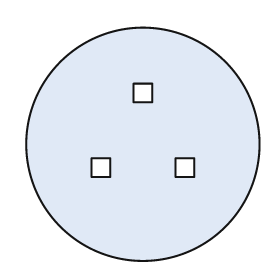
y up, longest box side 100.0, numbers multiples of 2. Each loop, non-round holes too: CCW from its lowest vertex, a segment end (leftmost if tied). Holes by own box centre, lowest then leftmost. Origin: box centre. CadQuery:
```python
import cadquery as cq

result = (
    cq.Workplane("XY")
    .moveTo(0.0, 0.0)
    .circle(50.0)
    .moveTo(-22.0, -14.0)
    .lineTo(-14.0, -14.0)
    .lineTo(-14.0, -6.0)
    .lineTo(-22.0, -6.0)
    .close()
    .moveTo(14.0, -14.0)
    .lineTo(22.0, -14.0)
    .lineTo(22.0, -6.0)
    .lineTo(14.0, -6.0)
    .close()
    .moveTo(-4.0, 18.0)
    .lineTo(4.0, 18.0)
    .lineTo(4.0, 26.0)
    .lineTo(-4.0, 26.0)
    .close()
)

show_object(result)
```